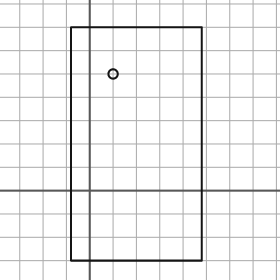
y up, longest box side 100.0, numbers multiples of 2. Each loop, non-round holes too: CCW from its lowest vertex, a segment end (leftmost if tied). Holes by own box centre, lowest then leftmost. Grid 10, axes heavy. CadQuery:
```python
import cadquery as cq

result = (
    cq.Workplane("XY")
    .moveTo(-8.0, -30.0)
    .lineTo(48.0, -30.0)
    .lineTo(48.0, 70.0)
    .lineTo(-8.0, 70.0)
    .close()
    .moveTo(10.0, 50.0)
    .circle(2.0)
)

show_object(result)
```